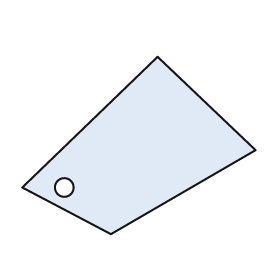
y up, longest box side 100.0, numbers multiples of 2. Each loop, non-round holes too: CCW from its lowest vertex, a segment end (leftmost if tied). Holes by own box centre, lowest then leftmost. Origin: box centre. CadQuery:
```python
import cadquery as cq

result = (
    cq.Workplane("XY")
    .moveTo(-12.0, -38.0)
    .lineTo(50.0, -2.0)
    .lineTo(8.0, 38.0)
    .lineTo(-50.0, -18.0)
    .close()
    .moveTo(-32.0, -18.0)
    .circle(4.0)
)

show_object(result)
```